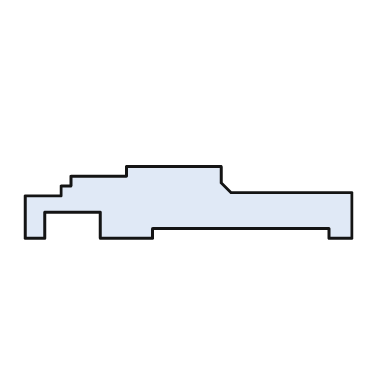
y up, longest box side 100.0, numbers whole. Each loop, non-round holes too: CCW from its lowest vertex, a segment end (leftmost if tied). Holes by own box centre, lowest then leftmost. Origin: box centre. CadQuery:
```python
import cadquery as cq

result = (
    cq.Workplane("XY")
    .moveTo(-50.0, -11.0)
    .lineTo(-44.0, -11.0)
    .lineTo(-44.0, -3.0)
    .lineTo(-27.0, -3.0)
    .lineTo(-27.0, -11.0)
    .lineTo(-11.0, -11.0)
    .lineTo(-11.0, -8.0)
    .lineTo(43.0, -8.0)
    .lineTo(43.0, -11.0)
    .lineTo(50.0, -11.0)
    .lineTo(50.0, 3.0)
    .lineTo(13.0, 3.0)
    .lineTo(10.0, 6.0)
    .lineTo(10.0, 11.0)
    .lineTo(-19.0, 11.0)
    .lineTo(-19.0, 8.0)
    .lineTo(-36.0, 8.0)
    .lineTo(-36.0, 5.0)
    .lineTo(-39.0, 5.0)
    .lineTo(-39.0, 2.0)
    .lineTo(-50.0, 2.0)
    .close()
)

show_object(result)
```